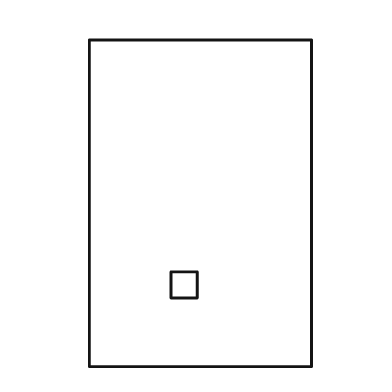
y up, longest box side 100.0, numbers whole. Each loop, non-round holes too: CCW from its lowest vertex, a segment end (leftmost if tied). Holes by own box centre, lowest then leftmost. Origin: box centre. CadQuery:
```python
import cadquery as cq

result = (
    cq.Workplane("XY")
    .moveTo(-34.0, -50.0)
    .lineTo(34.0, -50.0)
    .lineTo(34.0, 50.0)
    .lineTo(-34.0, 50.0)
    .close()
    .moveTo(-9.0, -29.0)
    .lineTo(-1.0, -29.0)
    .lineTo(-1.0, -21.0)
    .lineTo(-9.0, -21.0)
    .close()
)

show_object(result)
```